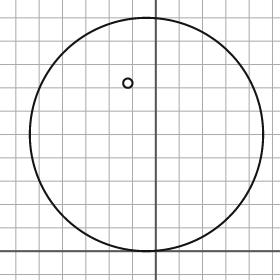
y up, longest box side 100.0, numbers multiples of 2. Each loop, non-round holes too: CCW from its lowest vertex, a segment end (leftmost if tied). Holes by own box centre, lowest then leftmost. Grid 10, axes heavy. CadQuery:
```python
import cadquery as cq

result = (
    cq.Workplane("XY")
    .moveTo(-4.0, 50.0)
    .circle(50.0)
    .moveTo(-12.0, 72.0)
    .circle(2.0)
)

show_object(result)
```